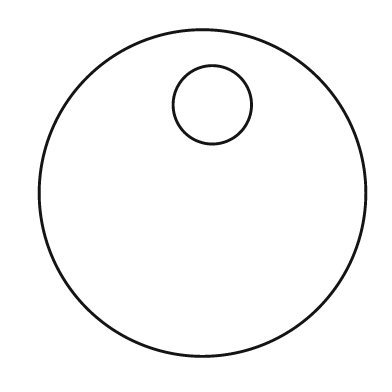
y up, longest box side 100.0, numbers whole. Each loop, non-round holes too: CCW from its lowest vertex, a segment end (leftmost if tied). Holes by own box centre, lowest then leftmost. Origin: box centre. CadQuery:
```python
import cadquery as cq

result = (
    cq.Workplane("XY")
    .moveTo(0.0, 0.0)
    .circle(50.0)
    .moveTo(3.0, 27.0)
    .circle(12.0)
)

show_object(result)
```